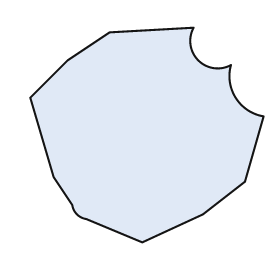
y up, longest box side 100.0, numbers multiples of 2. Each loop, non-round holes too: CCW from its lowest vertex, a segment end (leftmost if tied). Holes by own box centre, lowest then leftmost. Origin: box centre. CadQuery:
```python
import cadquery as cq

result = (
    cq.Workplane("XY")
    .moveTo(-2.0, -46.0)
    .lineTo(24.0, -34.0)
    .lineTo(42.0, -20.0)
    .lineTo(50.0, 8.0)
    .threePointArc((38.0, 16.0), (36.0, 30.0))
    .threePointArc((22.0, 32.0), (20.0, 46.0))
    .lineTo(-16.0, 44.0)
    .lineTo(-34.0, 32.0)
    .lineTo(-50.0, 16.0)
    .lineTo(-40.0, -18.0)
    .lineTo(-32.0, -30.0)
    .threePointArc((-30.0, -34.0), (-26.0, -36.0))
    .close()
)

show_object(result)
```